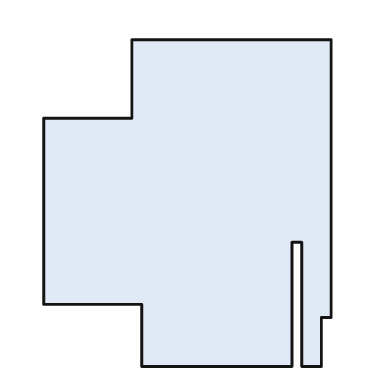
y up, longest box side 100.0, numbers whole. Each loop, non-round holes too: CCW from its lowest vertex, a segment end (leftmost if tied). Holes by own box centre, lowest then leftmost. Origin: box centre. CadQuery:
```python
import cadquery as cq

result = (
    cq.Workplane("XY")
    .moveTo(-14.0, -50.0)
    .lineTo(32.0, -50.0)
    .lineTo(32.0, -12.0)
    .lineTo(35.0, -12.0)
    .lineTo(35.0, -50.0)
    .lineTo(41.0, -50.0)
    .lineTo(41.0, -35.0)
    .lineTo(44.0, -35.0)
    .lineTo(44.0, 50.0)
    .lineTo(-17.0, 50.0)
    .lineTo(-17.0, 26.0)
    .lineTo(-44.0, 26.0)
    .lineTo(-44.0, -31.0)
    .lineTo(-14.0, -31.0)
    .close()
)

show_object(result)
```